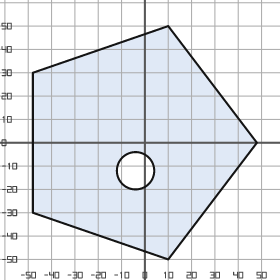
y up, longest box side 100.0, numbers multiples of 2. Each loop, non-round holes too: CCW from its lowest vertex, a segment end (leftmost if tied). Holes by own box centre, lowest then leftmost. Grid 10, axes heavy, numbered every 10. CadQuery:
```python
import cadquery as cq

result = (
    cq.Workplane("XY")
    .moveTo(10.0, -50.0)
    .lineTo(48.0, 0.0)
    .lineTo(10.0, 50.0)
    .lineTo(-48.0, 30.0)
    .lineTo(-48.0, -30.0)
    .close()
    .moveTo(-4.0, -12.0)
    .circle(8.0)
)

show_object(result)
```